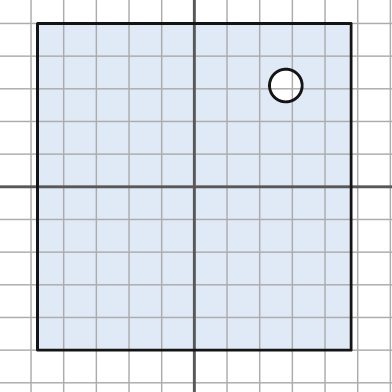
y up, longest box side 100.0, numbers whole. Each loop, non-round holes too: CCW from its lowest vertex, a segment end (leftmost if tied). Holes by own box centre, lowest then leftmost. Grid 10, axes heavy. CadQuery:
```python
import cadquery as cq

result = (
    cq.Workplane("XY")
    .moveTo(-48.0, -50.0)
    .lineTo(48.0, -50.0)
    .lineTo(48.0, 50.0)
    .lineTo(-48.0, 50.0)
    .close()
    .moveTo(28.0, 31.0)
    .circle(5.0)
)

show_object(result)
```